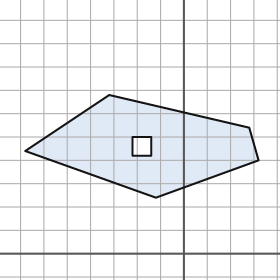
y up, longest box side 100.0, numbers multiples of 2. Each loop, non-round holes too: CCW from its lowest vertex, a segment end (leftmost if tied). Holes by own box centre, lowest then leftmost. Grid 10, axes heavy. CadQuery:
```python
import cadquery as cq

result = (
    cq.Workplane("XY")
    .moveTo(-12.0, 24.0)
    .lineTo(32.0, 40.0)
    .lineTo(28.0, 54.0)
    .lineTo(-32.0, 68.0)
    .lineTo(-68.0, 44.0)
    .close()
    .moveTo(-22.0, 42.0)
    .lineTo(-14.0, 42.0)
    .lineTo(-14.0, 50.0)
    .lineTo(-22.0, 50.0)
    .close()
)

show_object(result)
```